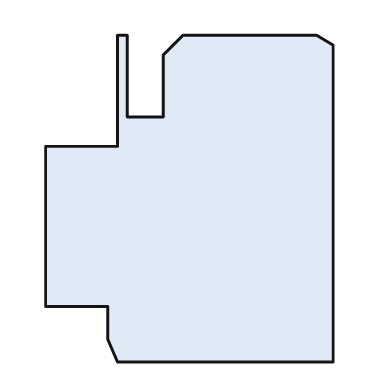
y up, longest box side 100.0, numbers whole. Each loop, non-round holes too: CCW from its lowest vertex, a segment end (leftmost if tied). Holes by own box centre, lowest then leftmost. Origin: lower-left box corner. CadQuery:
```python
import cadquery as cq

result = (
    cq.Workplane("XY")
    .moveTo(22.0, 0.0)
    .lineTo(88.0, 0.0)
    .lineTo(88.0, 97.0)
    .lineTo(83.0, 100.0)
    .lineTo(42.0, 100.0)
    .lineTo(36.0, 94.0)
    .lineTo(36.0, 75.0)
    .lineTo(25.0, 75.0)
    .lineTo(25.0, 100.0)
    .lineTo(22.0, 100.0)
    .lineTo(22.0, 66.0)
    .lineTo(0.0, 66.0)
    .lineTo(0.0, 17.0)
    .lineTo(19.0, 17.0)
    .lineTo(19.0, 7.0)
    .close()
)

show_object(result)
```